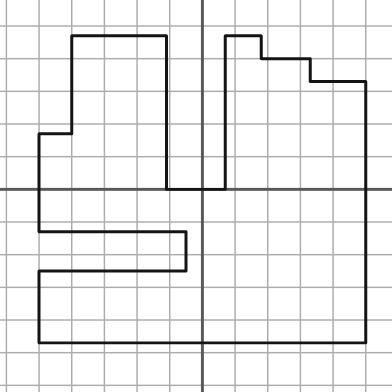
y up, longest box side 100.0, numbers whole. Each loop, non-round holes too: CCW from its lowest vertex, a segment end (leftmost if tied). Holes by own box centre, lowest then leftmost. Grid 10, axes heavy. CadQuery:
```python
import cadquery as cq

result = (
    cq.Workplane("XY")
    .moveTo(-50.0, -47.0)
    .lineTo(50.0, -47.0)
    .lineTo(50.0, 33.0)
    .lineTo(33.0, 33.0)
    .lineTo(33.0, 40.0)
    .lineTo(18.0, 40.0)
    .lineTo(18.0, 47.0)
    .lineTo(7.0, 47.0)
    .lineTo(7.0, 0.0)
    .lineTo(-11.0, 0.0)
    .lineTo(-11.0, 47.0)
    .lineTo(-40.0, 47.0)
    .lineTo(-40.0, 17.0)
    .lineTo(-50.0, 17.0)
    .lineTo(-50.0, -13.0)
    .lineTo(-5.0, -13.0)
    .lineTo(-5.0, -25.0)
    .lineTo(-50.0, -25.0)
    .close()
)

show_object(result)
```